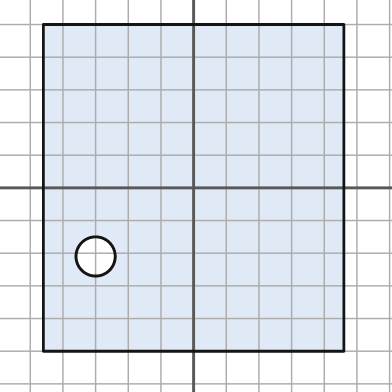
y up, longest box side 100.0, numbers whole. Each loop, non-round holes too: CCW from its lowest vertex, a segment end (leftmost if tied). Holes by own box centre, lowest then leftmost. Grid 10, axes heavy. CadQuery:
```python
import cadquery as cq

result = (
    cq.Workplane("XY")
    .moveTo(-46.0, -50.0)
    .lineTo(46.0, -50.0)
    .lineTo(46.0, 50.0)
    .lineTo(-46.0, 50.0)
    .close()
    .moveTo(-30.0, -21.0)
    .circle(6.0)
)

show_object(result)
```